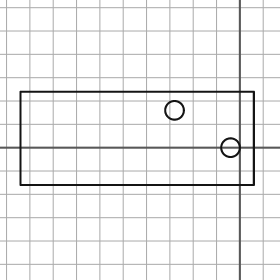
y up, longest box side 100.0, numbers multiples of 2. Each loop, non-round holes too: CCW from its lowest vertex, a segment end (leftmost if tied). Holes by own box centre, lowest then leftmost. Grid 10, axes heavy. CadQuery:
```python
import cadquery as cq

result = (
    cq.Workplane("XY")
    .moveTo(-94.0, -16.0)
    .lineTo(6.0, -16.0)
    .lineTo(6.0, 24.0)
    .lineTo(-94.0, 24.0)
    .close()
    .moveTo(-4.0, 0.0)
    .circle(4.0)
    .moveTo(-28.0, 16.0)
    .circle(4.0)
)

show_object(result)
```